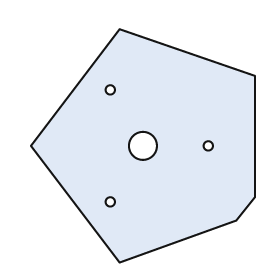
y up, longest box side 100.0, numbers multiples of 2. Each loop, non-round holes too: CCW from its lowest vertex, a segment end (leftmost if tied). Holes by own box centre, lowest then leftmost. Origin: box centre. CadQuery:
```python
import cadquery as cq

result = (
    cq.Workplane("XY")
    .moveTo(-10.0, -50.0)
    .lineTo(40.0, -32.0)
    .lineTo(48.0, -22.0)
    .lineTo(48.0, 30.0)
    .lineTo(-10.0, 50.0)
    .lineTo(-48.0, 0.0)
    .close()
    .moveTo(-14.0, -24.0)
    .circle(2.0)
    .moveTo(0.0, 0.0)
    .circle(6.0)
    .moveTo(28.0, 0.0)
    .circle(2.0)
    .moveTo(-14.0, 24.0)
    .circle(2.0)
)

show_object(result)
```